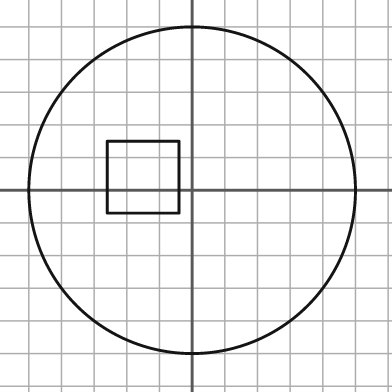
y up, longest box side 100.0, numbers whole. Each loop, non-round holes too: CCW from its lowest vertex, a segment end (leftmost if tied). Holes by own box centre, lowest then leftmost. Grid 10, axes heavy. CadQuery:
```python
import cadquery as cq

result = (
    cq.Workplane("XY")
    .moveTo(0.0, 0.0)
    .circle(50.0)
    .moveTo(-26.0, -7.0)
    .lineTo(-4.0, -7.0)
    .lineTo(-4.0, 15.0)
    .lineTo(-26.0, 15.0)
    .close()
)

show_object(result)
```